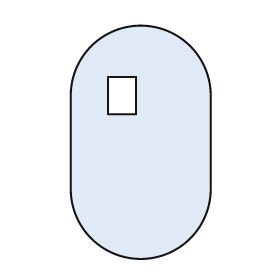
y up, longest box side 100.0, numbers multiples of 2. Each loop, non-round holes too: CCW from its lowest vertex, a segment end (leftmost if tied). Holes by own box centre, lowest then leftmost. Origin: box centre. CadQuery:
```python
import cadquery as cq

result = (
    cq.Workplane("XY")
    .moveTo(-30.0, -20.0)
    .threePointArc((0.0, -50.0), (30.0, -20.0))
    .lineTo(30.0, 20.0)
    .threePointArc((0.0, 50.0), (-30.0, 20.0))
    .close()
    .moveTo(-14.0, 12.0)
    .lineTo(-2.0, 12.0)
    .lineTo(-2.0, 28.0)
    .lineTo(-14.0, 28.0)
    .close()
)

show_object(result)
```